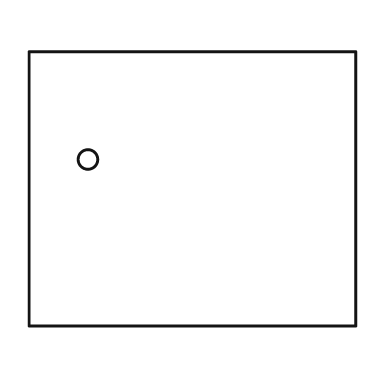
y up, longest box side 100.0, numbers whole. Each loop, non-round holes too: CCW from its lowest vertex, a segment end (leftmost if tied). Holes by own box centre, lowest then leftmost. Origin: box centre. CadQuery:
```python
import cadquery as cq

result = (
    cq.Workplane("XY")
    .moveTo(-50.0, -42.0)
    .lineTo(50.0, -42.0)
    .lineTo(50.0, 42.0)
    .lineTo(-50.0, 42.0)
    .close()
    .moveTo(-32.0, 9.0)
    .circle(3.0)
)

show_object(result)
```